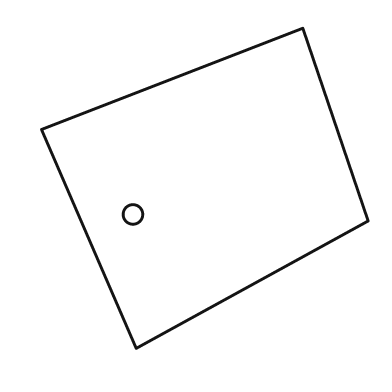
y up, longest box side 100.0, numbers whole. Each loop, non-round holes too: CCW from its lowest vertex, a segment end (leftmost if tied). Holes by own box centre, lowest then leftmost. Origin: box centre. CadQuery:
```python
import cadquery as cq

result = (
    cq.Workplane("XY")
    .moveTo(-21.0, -49.0)
    .lineTo(50.0, -10.0)
    .lineTo(30.0, 49.0)
    .lineTo(-50.0, 18.0)
    .close()
    .moveTo(-22.0, -8.0)
    .circle(3.0)
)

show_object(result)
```